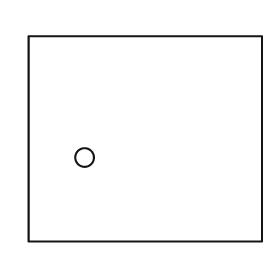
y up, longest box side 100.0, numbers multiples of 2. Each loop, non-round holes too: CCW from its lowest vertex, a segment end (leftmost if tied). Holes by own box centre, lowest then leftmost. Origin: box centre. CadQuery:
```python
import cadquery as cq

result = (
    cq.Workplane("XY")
    .moveTo(-50.0, -44.0)
    .lineTo(50.0, -44.0)
    .lineTo(50.0, 44.0)
    .lineTo(-50.0, 44.0)
    .close()
    .moveTo(-26.0, -8.0)
    .circle(4.0)
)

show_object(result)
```